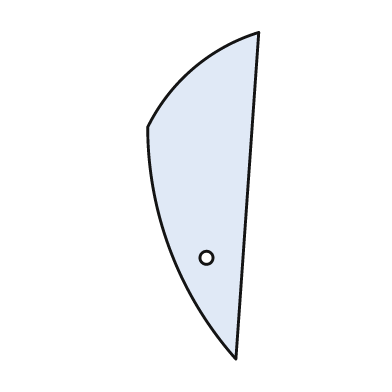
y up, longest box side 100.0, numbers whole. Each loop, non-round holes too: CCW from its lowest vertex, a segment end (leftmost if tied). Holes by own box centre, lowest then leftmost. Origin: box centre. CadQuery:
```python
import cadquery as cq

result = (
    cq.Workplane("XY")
    .moveTo(10.0, -50.0)
    .lineTo(17.0, 50.0)
    .threePointArc((-3.0, 39.0), (-17.0, 21.0))
    .threePointArc((-10.0, -17.0), (10.0, -50.0))
    .close()
    .moveTo(1.0, -19.0)
    .circle(2.0)
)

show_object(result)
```